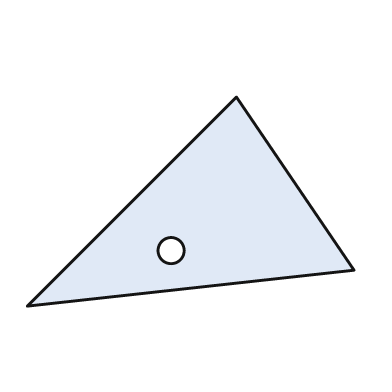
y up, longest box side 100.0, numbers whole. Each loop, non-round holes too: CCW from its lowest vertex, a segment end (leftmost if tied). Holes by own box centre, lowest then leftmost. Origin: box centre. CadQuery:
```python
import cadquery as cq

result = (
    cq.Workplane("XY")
    .moveTo(-50.0, -32.0)
    .lineTo(50.0, -21.0)
    .lineTo(14.0, 32.0)
    .close()
    .moveTo(-6.0, -15.0)
    .circle(4.0)
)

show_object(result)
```